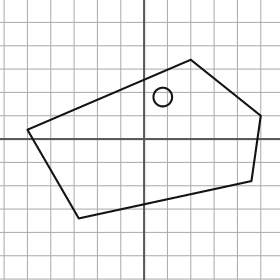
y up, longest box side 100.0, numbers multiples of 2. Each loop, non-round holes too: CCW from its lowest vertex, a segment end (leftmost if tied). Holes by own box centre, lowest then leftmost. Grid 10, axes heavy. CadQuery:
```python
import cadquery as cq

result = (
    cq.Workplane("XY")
    .moveTo(-28.0, -34.0)
    .lineTo(46.0, -18.0)
    .lineTo(50.0, 10.0)
    .lineTo(20.0, 34.0)
    .lineTo(-50.0, 4.0)
    .close()
    .moveTo(8.0, 18.0)
    .circle(4.0)
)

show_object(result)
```